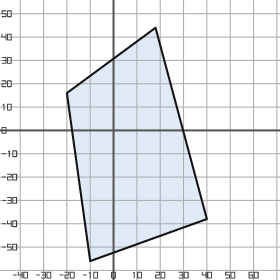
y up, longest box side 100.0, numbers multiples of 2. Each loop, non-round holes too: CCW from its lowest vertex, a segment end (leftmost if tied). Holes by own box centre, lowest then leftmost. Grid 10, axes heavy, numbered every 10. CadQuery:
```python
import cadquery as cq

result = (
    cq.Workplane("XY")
    .moveTo(-10.0, -56.0)
    .lineTo(40.0, -38.0)
    .lineTo(18.0, 44.0)
    .lineTo(-20.0, 16.0)
    .close()
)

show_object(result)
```